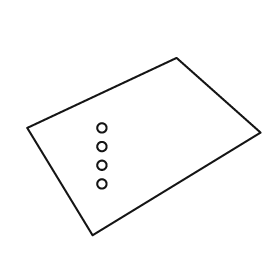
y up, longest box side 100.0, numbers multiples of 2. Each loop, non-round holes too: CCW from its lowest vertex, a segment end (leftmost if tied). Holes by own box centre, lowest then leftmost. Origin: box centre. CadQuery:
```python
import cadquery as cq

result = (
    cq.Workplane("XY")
    .moveTo(-22.0, -38.0)
    .lineTo(50.0, 6.0)
    .lineTo(14.0, 38.0)
    .lineTo(-50.0, 8.0)
    .close()
    .moveTo(-18.0, -16.0)
    .circle(2.0)
    .moveTo(-18.0, -8.0)
    .circle(2.0)
    .moveTo(-18.0, 0.0)
    .circle(2.0)
    .moveTo(-18.0, 8.0)
    .circle(2.0)
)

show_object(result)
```